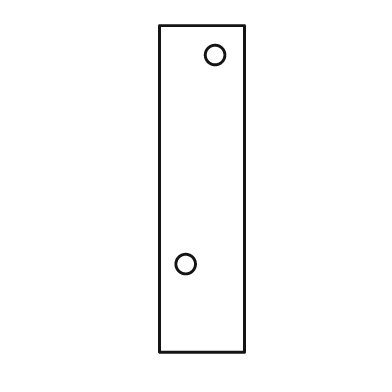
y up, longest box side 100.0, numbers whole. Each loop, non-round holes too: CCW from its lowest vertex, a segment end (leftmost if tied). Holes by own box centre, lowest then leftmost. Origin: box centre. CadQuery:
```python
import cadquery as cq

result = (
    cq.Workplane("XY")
    .moveTo(-13.0, -50.0)
    .lineTo(13.0, -50.0)
    .lineTo(13.0, 50.0)
    .lineTo(-13.0, 50.0)
    .close()
    .moveTo(-5.0, -23.0)
    .circle(3.0)
    .moveTo(4.0, 41.0)
    .circle(3.0)
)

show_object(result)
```